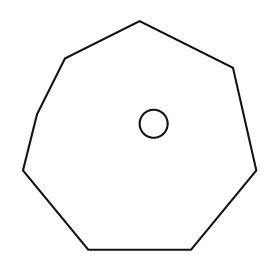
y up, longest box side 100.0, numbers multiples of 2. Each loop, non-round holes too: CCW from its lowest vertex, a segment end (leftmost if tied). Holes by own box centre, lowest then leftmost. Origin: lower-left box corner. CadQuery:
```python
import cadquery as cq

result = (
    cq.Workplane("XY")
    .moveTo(28.0, 0.0)
    .lineTo(72.0, 0.0)
    .lineTo(100.0, 34.0)
    .lineTo(90.0, 78.0)
    .lineTo(50.0, 98.0)
    .lineTo(18.0, 82.0)
    .lineTo(6.0, 58.0)
    .lineTo(0.0, 34.0)
    .close()
    .moveTo(56.0, 54.0)
    .circle(6.0)
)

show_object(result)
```